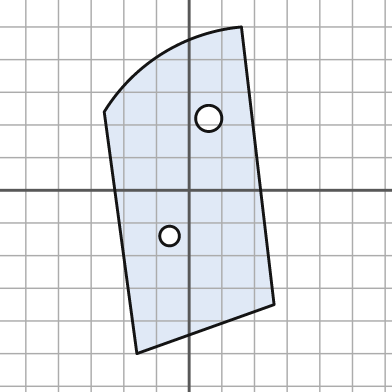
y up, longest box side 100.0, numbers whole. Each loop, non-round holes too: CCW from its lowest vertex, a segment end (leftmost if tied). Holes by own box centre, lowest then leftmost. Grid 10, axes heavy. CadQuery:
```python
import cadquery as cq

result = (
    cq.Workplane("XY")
    .moveTo(-16.0, -50.0)
    .lineTo(26.0, -35.0)
    .lineTo(16.0, 50.0)
    .threePointArc((-8.0, 42.0), (-26.0, 24.0))
    .close()
    .moveTo(-6.0, -14.0)
    .circle(3.0)
    .moveTo(6.0, 22.0)
    .circle(4.0)
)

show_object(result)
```